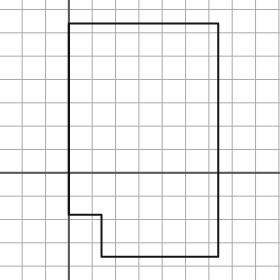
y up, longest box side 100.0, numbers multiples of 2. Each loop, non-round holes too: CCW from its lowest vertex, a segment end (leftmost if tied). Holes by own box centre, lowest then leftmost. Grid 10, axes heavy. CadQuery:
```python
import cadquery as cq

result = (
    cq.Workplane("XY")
    .moveTo(14.0, -36.0)
    .lineTo(64.0, -36.0)
    .lineTo(64.0, 64.0)
    .lineTo(0.0, 64.0)
    .lineTo(0.0, -18.0)
    .lineTo(14.0, -18.0)
    .close()
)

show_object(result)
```